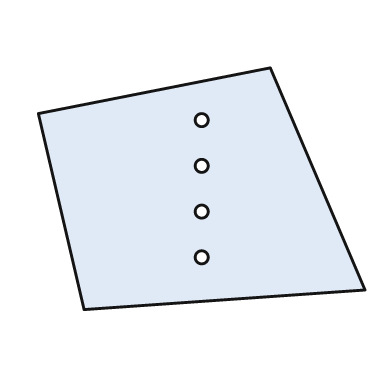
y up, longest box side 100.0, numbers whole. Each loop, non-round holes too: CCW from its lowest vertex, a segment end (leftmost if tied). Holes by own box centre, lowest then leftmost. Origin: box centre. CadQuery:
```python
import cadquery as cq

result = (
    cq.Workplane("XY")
    .moveTo(-36.0, -37.0)
    .lineTo(50.0, -31.0)
    .lineTo(21.0, 37.0)
    .lineTo(-50.0, 23.0)
    .close()
    .moveTo(0.0, -21.0)
    .circle(2.0)
    .moveTo(0.0, -7.0)
    .circle(2.0)
    .moveTo(0.0, 7.0)
    .circle(2.0)
    .moveTo(0.0, 21.0)
    .circle(2.0)
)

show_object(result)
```